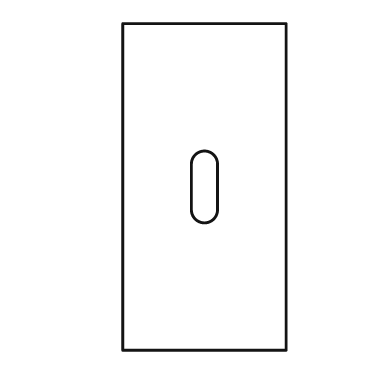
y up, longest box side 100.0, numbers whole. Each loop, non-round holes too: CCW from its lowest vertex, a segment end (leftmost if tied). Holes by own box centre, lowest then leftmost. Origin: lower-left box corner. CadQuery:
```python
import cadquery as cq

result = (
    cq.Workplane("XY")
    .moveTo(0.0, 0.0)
    .lineTo(50.0, 0.0)
    .lineTo(50.0, 100.0)
    .lineTo(0.0, 100.0)
    .close()
    .moveTo(21.0, 43.0)
    .threePointArc((25.0, 39.0), (29.0, 43.0))
    .lineTo(29.0, 57.0)
    .threePointArc((25.0, 61.0), (21.0, 57.0))
    .close()
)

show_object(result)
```